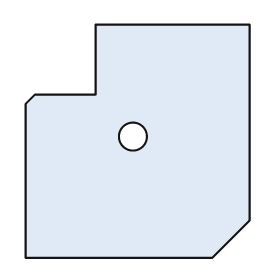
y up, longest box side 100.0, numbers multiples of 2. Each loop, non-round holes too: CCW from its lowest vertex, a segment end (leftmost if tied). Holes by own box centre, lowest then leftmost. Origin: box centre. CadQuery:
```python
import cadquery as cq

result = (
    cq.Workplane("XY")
    .moveTo(-48.0, -50.0)
    .lineTo(32.0, -50.0)
    .lineTo(48.0, -34.0)
    .lineTo(48.0, 50.0)
    .lineTo(-18.0, 50.0)
    .lineTo(-18.0, 20.0)
    .lineTo(-44.0, 20.0)
    .lineTo(-48.0, 16.0)
    .close()
    .moveTo(-2.0, 2.0)
    .circle(6.0)
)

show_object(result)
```